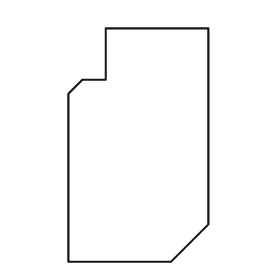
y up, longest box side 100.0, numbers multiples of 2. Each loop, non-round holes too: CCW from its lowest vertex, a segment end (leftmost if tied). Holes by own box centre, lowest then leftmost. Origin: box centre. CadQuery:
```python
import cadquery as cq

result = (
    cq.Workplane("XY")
    .moveTo(-30.0, -50.0)
    .lineTo(14.0, -50.0)
    .lineTo(30.0, -34.0)
    .lineTo(30.0, 50.0)
    .lineTo(-14.0, 50.0)
    .lineTo(-14.0, 28.0)
    .lineTo(-24.0, 28.0)
    .lineTo(-30.0, 22.0)
    .close()
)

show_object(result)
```